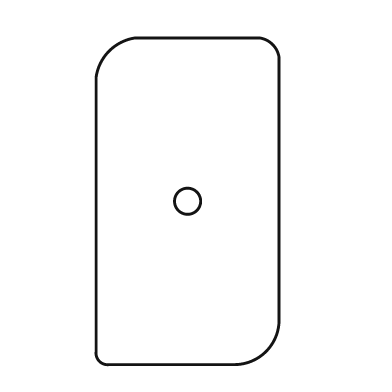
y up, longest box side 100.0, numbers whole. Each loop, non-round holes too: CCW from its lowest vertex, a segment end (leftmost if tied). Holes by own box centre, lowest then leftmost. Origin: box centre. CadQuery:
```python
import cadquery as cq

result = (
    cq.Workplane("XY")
    .moveTo(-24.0, -50.0)
    .lineTo(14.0, -50.0)
    .threePointArc((24.0, -46.0), (28.0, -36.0))
    .lineTo(28.0, 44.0)
    .threePointArc((26.0, 48.0), (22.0, 50.0))
    .lineTo(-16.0, 50.0)
    .threePointArc((-24.0, 46.0), (-28.0, 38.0))
    .lineTo(-28.0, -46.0)
    .threePointArc((-27.0, -49.0), (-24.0, -50.0))
    .close()
    .moveTo(0.0, 0.0)
    .circle(4.0)
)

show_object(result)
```